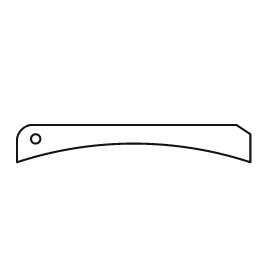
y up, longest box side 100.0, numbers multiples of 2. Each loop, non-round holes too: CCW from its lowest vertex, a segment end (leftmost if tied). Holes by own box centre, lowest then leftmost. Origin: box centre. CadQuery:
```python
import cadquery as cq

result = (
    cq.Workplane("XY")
    .moveTo(-50.0, -8.0)
    .threePointArc((0.0, 0.0), (50.0, -8.0))
    .lineTo(50.0, 4.0)
    .lineTo(44.0, 8.0)
    .lineTo(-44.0, 8.0)
    .threePointArc((-48.0, 6.0), (-50.0, 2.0))
    .close()
    .moveTo(-42.0, 2.0)
    .circle(2.0)
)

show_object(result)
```